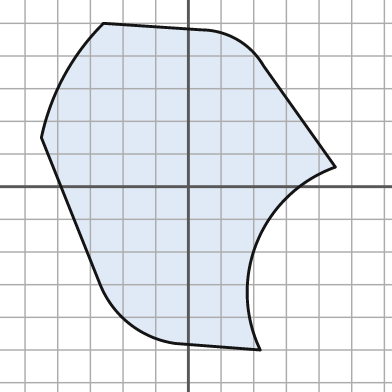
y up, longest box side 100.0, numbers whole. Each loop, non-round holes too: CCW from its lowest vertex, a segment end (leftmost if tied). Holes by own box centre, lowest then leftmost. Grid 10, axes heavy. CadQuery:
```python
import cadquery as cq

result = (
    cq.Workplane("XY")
    .moveTo(22.0, -50.0)
    .threePointArc((21.0, -17.0), (45.0, 6.0))
    .lineTo(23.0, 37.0)
    .threePointArc((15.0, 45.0), (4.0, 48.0))
    .lineTo(-26.0, 50.0)
    .threePointArc((-38.0, 34.0), (-45.0, 15.0))
    .lineTo(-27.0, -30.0)
    .threePointArc((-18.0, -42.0), (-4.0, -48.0))
    .close()
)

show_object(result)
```